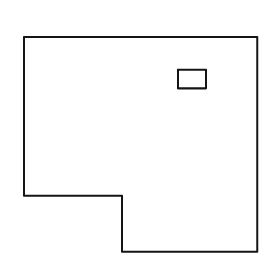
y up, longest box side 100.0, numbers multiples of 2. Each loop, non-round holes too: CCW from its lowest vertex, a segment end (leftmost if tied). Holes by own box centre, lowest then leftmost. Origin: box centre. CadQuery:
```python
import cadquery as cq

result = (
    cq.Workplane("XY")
    .moveTo(-8.0, -46.0)
    .lineTo(50.0, -46.0)
    .lineTo(50.0, 46.0)
    .lineTo(-50.0, 46.0)
    .lineTo(-50.0, -22.0)
    .lineTo(-8.0, -22.0)
    .close()
    .moveTo(16.0, 24.0)
    .lineTo(28.0, 24.0)
    .lineTo(28.0, 32.0)
    .lineTo(16.0, 32.0)
    .close()
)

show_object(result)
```